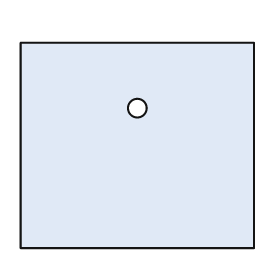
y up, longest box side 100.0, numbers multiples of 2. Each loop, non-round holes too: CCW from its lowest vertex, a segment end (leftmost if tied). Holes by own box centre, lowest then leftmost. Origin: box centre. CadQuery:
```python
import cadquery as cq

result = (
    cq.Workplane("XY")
    .moveTo(-50.0, -44.0)
    .lineTo(50.0, -44.0)
    .lineTo(50.0, 44.0)
    .lineTo(-50.0, 44.0)
    .close()
    .moveTo(0.0, 16.0)
    .circle(4.0)
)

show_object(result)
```